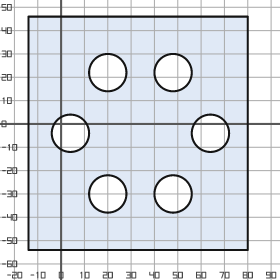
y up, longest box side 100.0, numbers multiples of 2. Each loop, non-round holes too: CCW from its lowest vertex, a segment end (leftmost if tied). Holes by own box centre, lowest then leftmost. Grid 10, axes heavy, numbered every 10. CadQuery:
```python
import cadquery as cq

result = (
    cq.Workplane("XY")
    .moveTo(-14.0, -54.0)
    .lineTo(80.0, -54.0)
    .lineTo(80.0, 46.0)
    .lineTo(-14.0, 46.0)
    .close()
    .moveTo(20.0, -30.0)
    .circle(8.0)
    .moveTo(48.0, -30.0)
    .circle(8.0)
    .moveTo(4.0, -4.0)
    .circle(8.0)
    .moveTo(64.0, -4.0)
    .circle(8.0)
    .moveTo(20.0, 22.0)
    .circle(8.0)
    .moveTo(48.0, 22.0)
    .circle(8.0)
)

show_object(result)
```